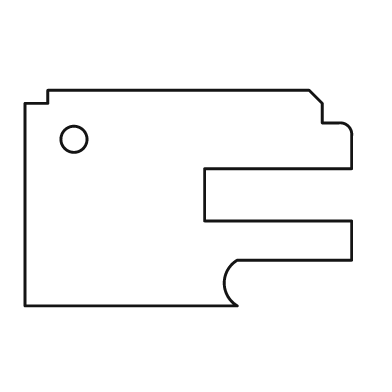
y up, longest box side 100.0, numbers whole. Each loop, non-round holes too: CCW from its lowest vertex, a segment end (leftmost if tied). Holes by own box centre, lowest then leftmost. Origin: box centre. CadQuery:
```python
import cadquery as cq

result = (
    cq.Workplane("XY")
    .moveTo(-50.0, -33.0)
    .lineTo(15.0, -33.0)
    .threePointArc((11.0, -26.0), (15.0, -19.0))
    .lineTo(50.0, -19.0)
    .lineTo(50.0, -7.0)
    .lineTo(5.0, -7.0)
    .lineTo(5.0, 9.0)
    .lineTo(50.0, 9.0)
    .lineTo(50.0, 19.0)
    .threePointArc((49.0, 22.0), (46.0, 23.0))
    .lineTo(41.0, 23.0)
    .lineTo(41.0, 29.0)
    .lineTo(37.0, 33.0)
    .lineTo(-43.0, 33.0)
    .lineTo(-43.0, 29.0)
    .lineTo(-50.0, 29.0)
    .close()
    .moveTo(-35.0, 18.0)
    .circle(4.0)
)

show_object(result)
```